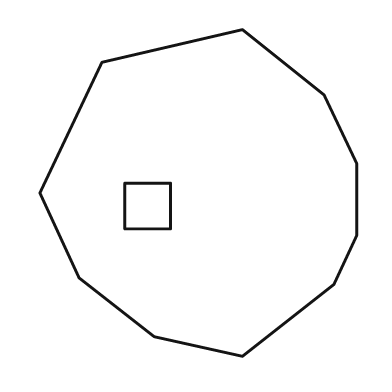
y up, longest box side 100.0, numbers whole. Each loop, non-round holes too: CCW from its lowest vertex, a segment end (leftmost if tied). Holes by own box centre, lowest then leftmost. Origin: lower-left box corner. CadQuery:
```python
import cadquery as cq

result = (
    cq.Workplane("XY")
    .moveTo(62.0, 0.0)
    .lineTo(90.0, 22.0)
    .lineTo(97.0, 37.0)
    .lineTo(97.0, 59.0)
    .lineTo(87.0, 80.0)
    .lineTo(62.0, 100.0)
    .lineTo(19.0, 90.0)
    .lineTo(0.0, 50.0)
    .lineTo(12.0, 24.0)
    .lineTo(35.0, 6.0)
    .close()
    .moveTo(26.0, 39.0)
    .lineTo(40.0, 39.0)
    .lineTo(40.0, 53.0)
    .lineTo(26.0, 53.0)
    .close()
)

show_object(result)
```